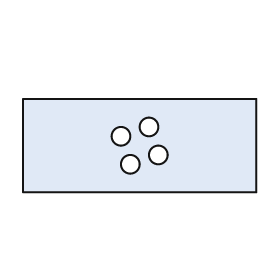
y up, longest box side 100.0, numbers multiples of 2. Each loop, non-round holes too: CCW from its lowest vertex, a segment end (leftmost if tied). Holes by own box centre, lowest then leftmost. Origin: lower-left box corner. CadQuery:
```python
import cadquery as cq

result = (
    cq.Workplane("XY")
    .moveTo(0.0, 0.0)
    .lineTo(100.0, 0.0)
    .lineTo(100.0, 40.0)
    .lineTo(0.0, 40.0)
    .close()
    .moveTo(46.0, 12.0)
    .circle(4.0)
    .moveTo(58.0, 16.0)
    .circle(4.0)
    .moveTo(42.0, 24.0)
    .circle(4.0)
    .moveTo(54.0, 28.0)
    .circle(4.0)
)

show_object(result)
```